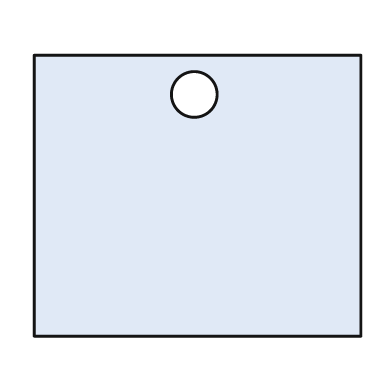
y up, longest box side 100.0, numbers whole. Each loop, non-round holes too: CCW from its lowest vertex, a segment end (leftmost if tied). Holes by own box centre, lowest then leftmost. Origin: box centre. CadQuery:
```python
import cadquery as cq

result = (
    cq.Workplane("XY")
    .moveTo(-50.0, -43.0)
    .lineTo(50.0, -43.0)
    .lineTo(50.0, 43.0)
    .lineTo(-50.0, 43.0)
    .close()
    .moveTo(-1.0, 31.0)
    .circle(7.0)
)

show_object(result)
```